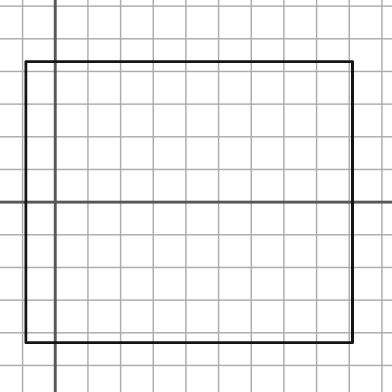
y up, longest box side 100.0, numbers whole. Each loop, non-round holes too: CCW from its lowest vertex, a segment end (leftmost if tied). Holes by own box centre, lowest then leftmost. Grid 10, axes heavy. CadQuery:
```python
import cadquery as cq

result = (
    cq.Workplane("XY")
    .moveTo(-9.0, -43.0)
    .lineTo(91.0, -43.0)
    .lineTo(91.0, 43.0)
    .lineTo(-9.0, 43.0)
    .close()
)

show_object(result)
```